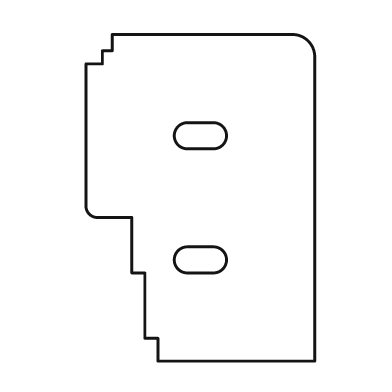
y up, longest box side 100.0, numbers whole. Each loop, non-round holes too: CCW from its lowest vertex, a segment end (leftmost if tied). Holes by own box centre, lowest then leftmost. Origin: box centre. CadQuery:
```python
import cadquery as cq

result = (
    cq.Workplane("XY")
    .moveTo(-13.0, -50.0)
    .lineTo(35.0, -50.0)
    .lineTo(35.0, 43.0)
    .threePointArc((33.0, 48.0), (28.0, 50.0))
    .lineTo(-27.0, 50.0)
    .lineTo(-27.0, 45.0)
    .lineTo(-30.0, 45.0)
    .lineTo(-30.0, 41.0)
    .lineTo(-35.0, 41.0)
    .lineTo(-35.0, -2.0)
    .threePointArc((-34.0, -5.0), (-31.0, -6.0))
    .lineTo(-21.0, -6.0)
    .lineTo(-21.0, -23.0)
    .lineTo(-17.0, -23.0)
    .lineTo(-17.0, -43.0)
    .lineTo(-13.0, -43.0)
    .close()
    .moveTo(-4.0, -23.0)
    .lineTo(4.0, -23.0)
    .threePointArc((8.0, -19.0), (4.0, -15.0))
    .lineTo(-4.0, -15.0)
    .threePointArc((-8.0, -19.0), (-4.0, -23.0))
    .close()
    .moveTo(-4.0, 15.0)
    .lineTo(4.0, 15.0)
    .threePointArc((8.0, 19.0), (4.0, 23.0))
    .lineTo(-4.0, 23.0)
    .threePointArc((-8.0, 19.0), (-4.0, 15.0))
    .close()
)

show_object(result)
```